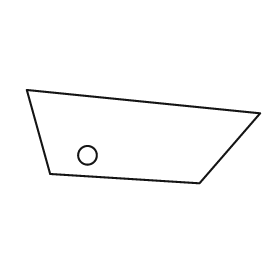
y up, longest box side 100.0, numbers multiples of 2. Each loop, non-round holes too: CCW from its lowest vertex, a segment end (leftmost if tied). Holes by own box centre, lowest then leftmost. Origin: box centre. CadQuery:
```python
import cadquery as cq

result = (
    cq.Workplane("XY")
    .moveTo(24.0, -20.0)
    .lineTo(50.0, 10.0)
    .lineTo(-50.0, 20.0)
    .lineTo(-40.0, -16.0)
    .close()
    .moveTo(-24.0, -8.0)
    .circle(4.0)
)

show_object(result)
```